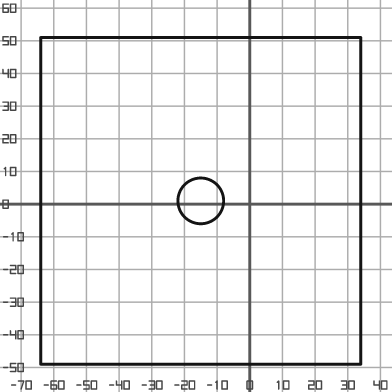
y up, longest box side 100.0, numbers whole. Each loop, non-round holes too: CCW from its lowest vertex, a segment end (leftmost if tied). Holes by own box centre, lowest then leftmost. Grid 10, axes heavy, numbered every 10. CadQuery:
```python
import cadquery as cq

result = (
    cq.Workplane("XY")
    .moveTo(-64.0, -49.0)
    .lineTo(34.0, -49.0)
    .lineTo(34.0, 51.0)
    .lineTo(-64.0, 51.0)
    .close()
    .moveTo(-15.0, 1.0)
    .circle(7.0)
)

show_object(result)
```